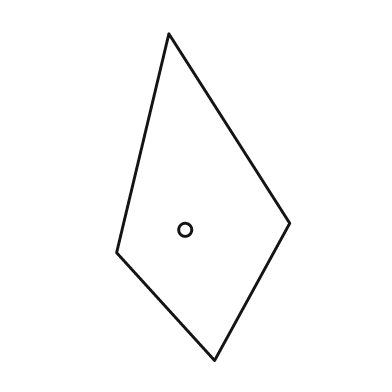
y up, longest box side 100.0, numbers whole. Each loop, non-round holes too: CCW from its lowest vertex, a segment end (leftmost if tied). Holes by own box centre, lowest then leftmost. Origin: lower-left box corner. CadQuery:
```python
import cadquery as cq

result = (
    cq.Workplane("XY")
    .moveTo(30.0, 0.0)
    .lineTo(53.0, 42.0)
    .lineTo(16.0, 100.0)
    .lineTo(0.0, 33.0)
    .close()
    .moveTo(21.0, 40.0)
    .circle(2.0)
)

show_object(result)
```